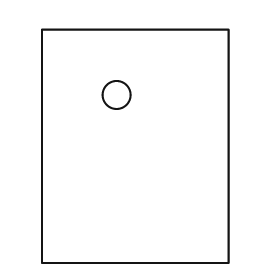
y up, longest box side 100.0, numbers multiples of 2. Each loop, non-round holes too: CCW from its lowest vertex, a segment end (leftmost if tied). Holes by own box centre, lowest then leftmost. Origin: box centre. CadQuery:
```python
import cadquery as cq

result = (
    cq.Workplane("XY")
    .moveTo(-40.0, -50.0)
    .lineTo(40.0, -50.0)
    .lineTo(40.0, 50.0)
    .lineTo(-40.0, 50.0)
    .close()
    .moveTo(-8.0, 22.0)
    .circle(6.0)
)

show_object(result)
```